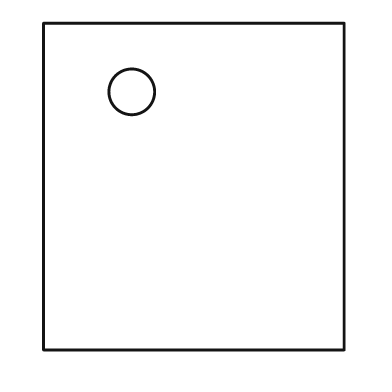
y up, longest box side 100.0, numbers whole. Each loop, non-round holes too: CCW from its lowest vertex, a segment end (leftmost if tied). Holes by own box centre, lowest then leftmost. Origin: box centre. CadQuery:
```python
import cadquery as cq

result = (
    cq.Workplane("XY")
    .moveTo(-46.0, -50.0)
    .lineTo(46.0, -50.0)
    .lineTo(46.0, 50.0)
    .lineTo(-46.0, 50.0)
    .close()
    .moveTo(-19.0, 29.0)
    .circle(7.0)
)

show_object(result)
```